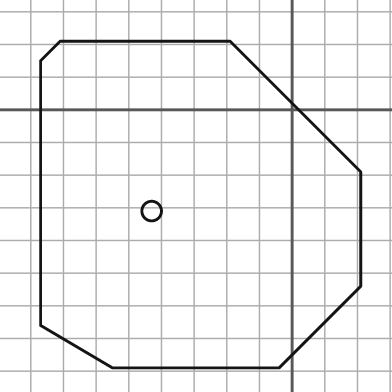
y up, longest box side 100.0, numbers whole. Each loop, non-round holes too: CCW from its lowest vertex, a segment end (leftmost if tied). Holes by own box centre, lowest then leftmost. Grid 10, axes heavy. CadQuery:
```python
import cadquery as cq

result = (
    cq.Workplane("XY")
    .moveTo(-55.0, -79.0)
    .lineTo(-4.0, -79.0)
    .lineTo(21.0, -54.0)
    .lineTo(21.0, -19.0)
    .lineTo(-19.0, 21.0)
    .lineTo(-71.0, 21.0)
    .lineTo(-77.0, 15.0)
    .lineTo(-77.0, -66.0)
    .close()
    .moveTo(-43.0, -31.0)
    .circle(3.0)
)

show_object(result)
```